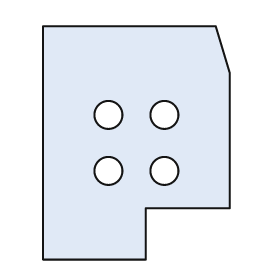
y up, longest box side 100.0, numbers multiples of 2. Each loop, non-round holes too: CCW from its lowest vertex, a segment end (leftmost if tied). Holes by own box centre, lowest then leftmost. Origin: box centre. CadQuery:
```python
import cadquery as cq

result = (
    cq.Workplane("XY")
    .moveTo(-40.0, -50.0)
    .lineTo(4.0, -50.0)
    .lineTo(4.0, -28.0)
    .lineTo(40.0, -28.0)
    .lineTo(40.0, 30.0)
    .lineTo(34.0, 50.0)
    .lineTo(-40.0, 50.0)
    .close()
    .moveTo(-12.0, -12.0)
    .circle(6.0)
    .moveTo(12.0, -12.0)
    .circle(6.0)
    .moveTo(-12.0, 12.0)
    .circle(6.0)
    .moveTo(12.0, 12.0)
    .circle(6.0)
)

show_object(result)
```